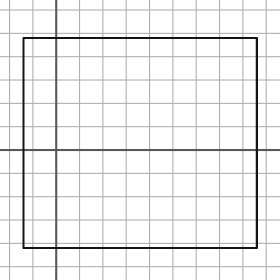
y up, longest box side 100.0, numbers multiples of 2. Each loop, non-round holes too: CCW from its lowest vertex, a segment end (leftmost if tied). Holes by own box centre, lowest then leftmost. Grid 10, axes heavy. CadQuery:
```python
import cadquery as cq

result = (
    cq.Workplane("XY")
    .moveTo(-14.0, -42.0)
    .lineTo(86.0, -42.0)
    .lineTo(86.0, 48.0)
    .lineTo(-14.0, 48.0)
    .close()
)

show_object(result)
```